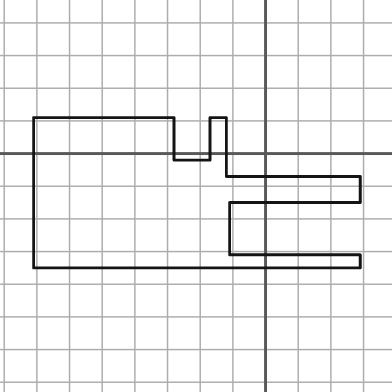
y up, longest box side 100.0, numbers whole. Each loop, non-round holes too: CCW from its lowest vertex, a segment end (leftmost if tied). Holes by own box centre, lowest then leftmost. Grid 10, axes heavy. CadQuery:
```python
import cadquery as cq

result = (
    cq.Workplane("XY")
    .moveTo(-71.0, -35.0)
    .lineTo(29.0, -35.0)
    .lineTo(29.0, -31.0)
    .lineTo(-11.0, -31.0)
    .lineTo(-11.0, -15.0)
    .lineTo(29.0, -15.0)
    .lineTo(29.0, -7.0)
    .lineTo(-12.0, -7.0)
    .lineTo(-12.0, 11.0)
    .lineTo(-17.0, 11.0)
    .lineTo(-17.0, -2.0)
    .lineTo(-28.0, -2.0)
    .lineTo(-28.0, 11.0)
    .lineTo(-71.0, 11.0)
    .close()
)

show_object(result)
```